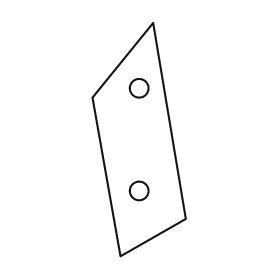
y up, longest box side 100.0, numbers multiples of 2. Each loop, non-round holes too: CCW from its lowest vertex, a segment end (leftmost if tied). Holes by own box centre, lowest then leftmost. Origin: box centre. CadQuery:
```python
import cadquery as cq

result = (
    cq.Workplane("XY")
    .moveTo(-8.0, -50.0)
    .lineTo(20.0, -34.0)
    .lineTo(6.0, 50.0)
    .lineTo(-20.0, 18.0)
    .close()
    .moveTo(0.0, -22.0)
    .circle(4.0)
    .moveTo(0.0, 22.0)
    .circle(4.0)
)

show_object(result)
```